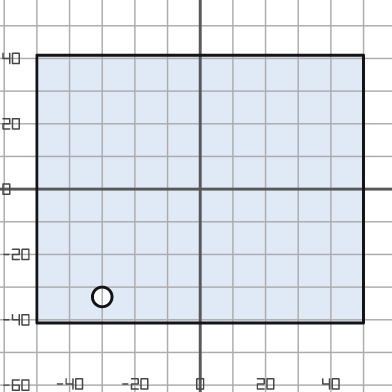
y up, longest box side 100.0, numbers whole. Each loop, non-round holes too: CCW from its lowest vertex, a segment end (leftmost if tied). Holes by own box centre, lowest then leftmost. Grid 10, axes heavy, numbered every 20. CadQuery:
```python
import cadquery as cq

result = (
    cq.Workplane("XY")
    .moveTo(-50.0, -41.0)
    .lineTo(50.0, -41.0)
    .lineTo(50.0, 41.0)
    .lineTo(-50.0, 41.0)
    .close()
    .moveTo(-30.0, -33.0)
    .circle(3.0)
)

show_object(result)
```